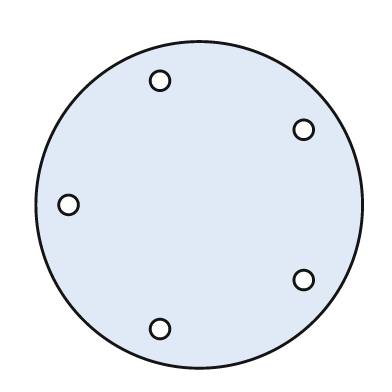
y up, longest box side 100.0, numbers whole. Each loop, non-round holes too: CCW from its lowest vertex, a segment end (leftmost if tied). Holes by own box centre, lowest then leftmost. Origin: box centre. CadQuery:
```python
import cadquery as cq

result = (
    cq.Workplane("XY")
    .moveTo(0.0, 0.0)
    .circle(50.0)
    .moveTo(-12.0, -38.0)
    .circle(3.0)
    .moveTo(32.0, -23.0)
    .circle(3.0)
    .moveTo(-40.0, 0.0)
    .circle(3.0)
    .moveTo(32.0, 23.0)
    .circle(3.0)
    .moveTo(-12.0, 38.0)
    .circle(3.0)
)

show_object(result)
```